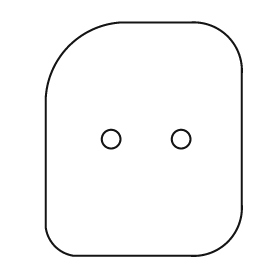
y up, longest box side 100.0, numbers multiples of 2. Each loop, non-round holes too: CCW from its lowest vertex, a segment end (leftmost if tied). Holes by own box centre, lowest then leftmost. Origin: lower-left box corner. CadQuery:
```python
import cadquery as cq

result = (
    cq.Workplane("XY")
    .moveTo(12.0, 0.0)
    .lineTo(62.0, 0.0)
    .threePointArc((78.0, 6.0), (84.0, 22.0))
    .lineTo(84.0, 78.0)
    .threePointArc((78.0, 94.0), (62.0, 100.0))
    .lineTo(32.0, 100.0)
    .threePointArc((10.0, 90.0), (0.0, 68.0))
    .lineTo(0.0, 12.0)
    .threePointArc((4.0, 4.0), (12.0, 0.0))
    .close()
    .moveTo(28.0, 50.0)
    .circle(4.0)
    .moveTo(58.0, 50.0)
    .circle(4.0)
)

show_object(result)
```